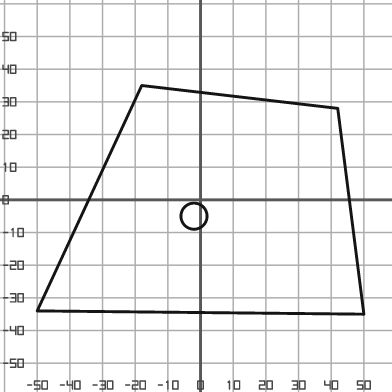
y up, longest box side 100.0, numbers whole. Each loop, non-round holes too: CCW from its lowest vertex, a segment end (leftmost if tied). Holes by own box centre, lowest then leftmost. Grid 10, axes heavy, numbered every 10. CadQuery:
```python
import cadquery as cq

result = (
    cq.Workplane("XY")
    .moveTo(50.0, -35.0)
    .lineTo(42.0, 28.0)
    .lineTo(-18.0, 35.0)
    .lineTo(-50.0, -34.0)
    .close()
    .moveTo(-2.0, -5.0)
    .circle(4.0)
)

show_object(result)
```